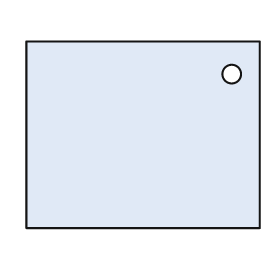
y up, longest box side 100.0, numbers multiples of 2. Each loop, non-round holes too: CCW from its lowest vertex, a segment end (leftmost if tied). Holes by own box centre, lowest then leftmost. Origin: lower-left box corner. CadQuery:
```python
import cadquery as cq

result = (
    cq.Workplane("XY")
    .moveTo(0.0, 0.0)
    .lineTo(100.0, 0.0)
    .lineTo(100.0, 80.0)
    .lineTo(0.0, 80.0)
    .close()
    .moveTo(88.0, 66.0)
    .circle(4.0)
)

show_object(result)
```